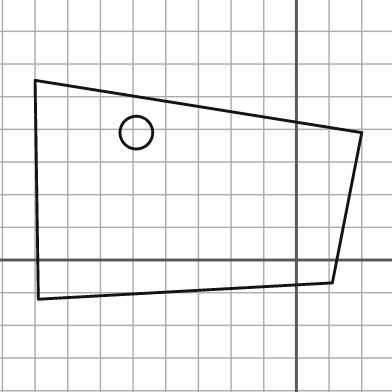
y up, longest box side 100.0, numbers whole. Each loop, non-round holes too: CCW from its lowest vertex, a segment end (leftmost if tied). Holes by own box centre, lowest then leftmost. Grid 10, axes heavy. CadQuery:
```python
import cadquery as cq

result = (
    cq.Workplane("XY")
    .moveTo(-79.0, -12.0)
    .lineTo(11.0, -7.0)
    .lineTo(20.0, 39.0)
    .lineTo(-80.0, 55.0)
    .close()
    .moveTo(-49.0, 39.0)
    .circle(5.0)
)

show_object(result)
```